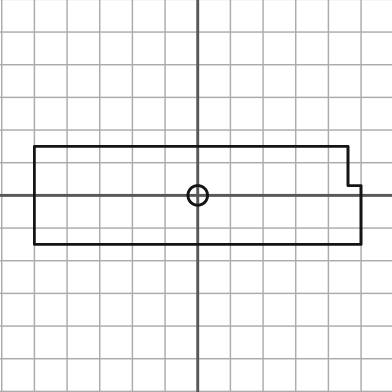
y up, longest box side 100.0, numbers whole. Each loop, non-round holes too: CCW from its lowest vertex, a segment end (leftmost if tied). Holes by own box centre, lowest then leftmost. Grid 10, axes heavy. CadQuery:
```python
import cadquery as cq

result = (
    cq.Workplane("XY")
    .moveTo(-50.0, -15.0)
    .lineTo(50.0, -15.0)
    .lineTo(50.0, 3.0)
    .lineTo(46.0, 3.0)
    .lineTo(46.0, 15.0)
    .lineTo(-50.0, 15.0)
    .close()
    .moveTo(0.0, 0.0)
    .circle(3.0)
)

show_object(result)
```